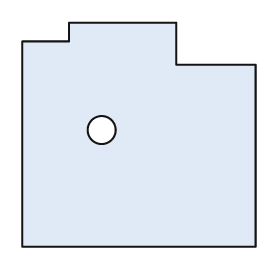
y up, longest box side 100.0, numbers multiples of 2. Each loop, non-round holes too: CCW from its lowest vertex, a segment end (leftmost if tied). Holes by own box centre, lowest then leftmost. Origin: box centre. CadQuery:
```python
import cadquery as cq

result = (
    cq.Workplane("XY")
    .moveTo(-50.0, -48.0)
    .lineTo(50.0, -48.0)
    .lineTo(50.0, 30.0)
    .lineTo(16.0, 30.0)
    .lineTo(16.0, 48.0)
    .lineTo(-30.0, 48.0)
    .lineTo(-30.0, 40.0)
    .lineTo(-50.0, 40.0)
    .close()
    .moveTo(-16.0, 2.0)
    .circle(6.0)
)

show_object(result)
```